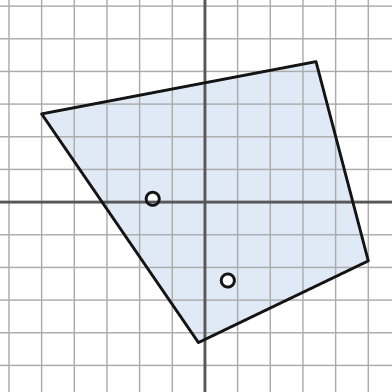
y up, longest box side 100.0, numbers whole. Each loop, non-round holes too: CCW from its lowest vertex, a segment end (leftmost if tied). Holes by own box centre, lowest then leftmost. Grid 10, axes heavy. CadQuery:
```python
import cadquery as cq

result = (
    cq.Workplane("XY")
    .moveTo(-2.0, -43.0)
    .lineTo(50.0, -18.0)
    .lineTo(34.0, 43.0)
    .lineTo(-50.0, 27.0)
    .close()
    .moveTo(7.0, -24.0)
    .circle(2.0)
    .moveTo(-16.0, 1.0)
    .circle(2.0)
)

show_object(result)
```